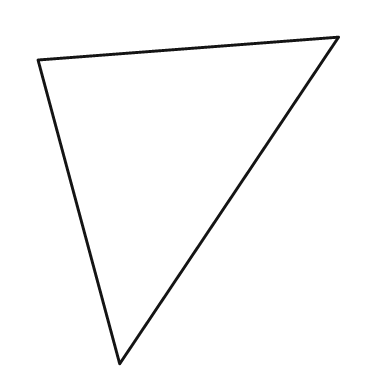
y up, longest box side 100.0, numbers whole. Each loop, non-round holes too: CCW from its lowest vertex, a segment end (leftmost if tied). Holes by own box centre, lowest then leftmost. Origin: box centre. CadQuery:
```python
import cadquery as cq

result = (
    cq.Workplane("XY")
    .moveTo(-21.0, -50.0)
    .lineTo(46.0, 50.0)
    .lineTo(-46.0, 43.0)
    .close()
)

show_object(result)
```